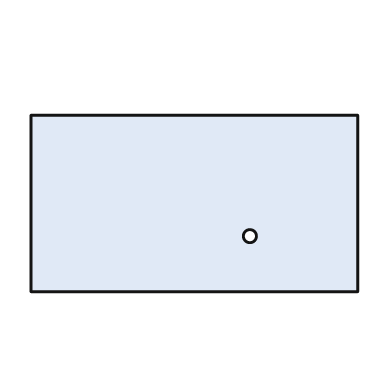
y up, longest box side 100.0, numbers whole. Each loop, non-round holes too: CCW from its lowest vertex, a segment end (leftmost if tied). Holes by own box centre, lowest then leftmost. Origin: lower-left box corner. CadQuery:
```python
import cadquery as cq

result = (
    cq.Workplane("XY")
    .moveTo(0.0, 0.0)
    .lineTo(100.0, 0.0)
    .lineTo(100.0, 54.0)
    .lineTo(0.0, 54.0)
    .close()
    .moveTo(67.0, 17.0)
    .circle(2.0)
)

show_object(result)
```